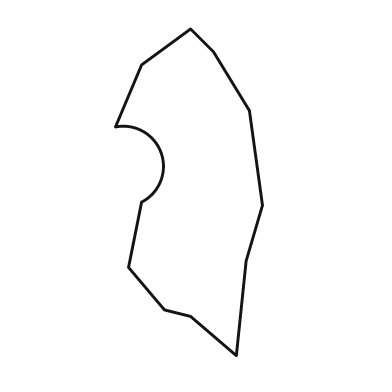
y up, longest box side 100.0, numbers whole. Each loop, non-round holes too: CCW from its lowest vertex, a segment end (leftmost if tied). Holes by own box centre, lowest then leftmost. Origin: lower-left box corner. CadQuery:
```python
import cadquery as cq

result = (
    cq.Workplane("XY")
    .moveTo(37.0, 0.0)
    .lineTo(40.0, 29.0)
    .lineTo(45.0, 46.0)
    .lineTo(41.0, 75.0)
    .lineTo(30.0, 93.0)
    .lineTo(23.0, 100.0)
    .lineTo(8.0, 89.0)
    .lineTo(0.0, 70.0)
    .threePointArc((14.0, 62.0), (8.0, 47.0))
    .lineTo(4.0, 27.0)
    .lineTo(15.0, 14.0)
    .lineTo(23.0, 12.0)
    .close()
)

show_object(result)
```